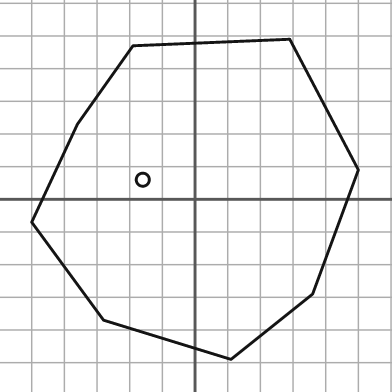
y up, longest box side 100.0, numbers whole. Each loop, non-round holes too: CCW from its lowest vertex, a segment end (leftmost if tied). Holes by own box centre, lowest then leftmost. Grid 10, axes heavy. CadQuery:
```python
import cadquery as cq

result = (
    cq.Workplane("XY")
    .moveTo(11.0, -49.0)
    .lineTo(36.0, -29.0)
    .lineTo(50.0, 9.0)
    .lineTo(29.0, 49.0)
    .lineTo(-19.0, 47.0)
    .lineTo(-36.0, 23.0)
    .lineTo(-50.0, -7.0)
    .lineTo(-28.0, -37.0)
    .close()
    .moveTo(-16.0, 6.0)
    .circle(2.0)
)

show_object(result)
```